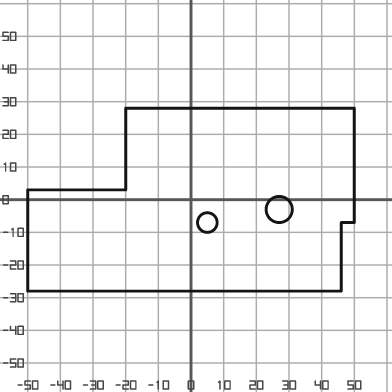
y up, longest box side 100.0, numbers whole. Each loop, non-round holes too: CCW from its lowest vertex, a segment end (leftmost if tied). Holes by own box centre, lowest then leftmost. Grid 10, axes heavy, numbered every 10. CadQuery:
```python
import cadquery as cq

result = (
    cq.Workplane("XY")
    .moveTo(-50.0, -28.0)
    .lineTo(46.0, -28.0)
    .lineTo(46.0, -7.0)
    .lineTo(50.0, -7.0)
    .lineTo(50.0, 28.0)
    .lineTo(-20.0, 28.0)
    .lineTo(-20.0, 3.0)
    .lineTo(-50.0, 3.0)
    .close()
    .moveTo(5.0, -7.0)
    .circle(3.0)
    .moveTo(27.0, -3.0)
    .circle(4.0)
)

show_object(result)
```